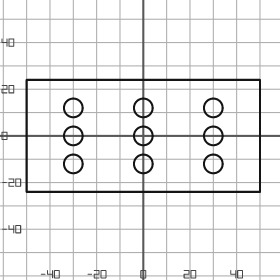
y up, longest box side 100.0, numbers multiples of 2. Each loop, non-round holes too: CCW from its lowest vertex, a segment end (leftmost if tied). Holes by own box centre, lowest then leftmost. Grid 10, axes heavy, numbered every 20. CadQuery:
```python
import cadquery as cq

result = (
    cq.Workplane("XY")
    .moveTo(-50.0, -24.0)
    .lineTo(50.0, -24.0)
    .lineTo(50.0, 24.0)
    .lineTo(-50.0, 24.0)
    .close()
    .moveTo(-30.0, -12.0)
    .circle(4.0)
    .moveTo(0.0, -12.0)
    .circle(4.0)
    .moveTo(30.0, -12.0)
    .circle(4.0)
    .moveTo(-30.0, 0.0)
    .circle(4.0)
    .moveTo(0.0, 0.0)
    .circle(4.0)
    .moveTo(30.0, 0.0)
    .circle(4.0)
    .moveTo(-30.0, 12.0)
    .circle(4.0)
    .moveTo(0.0, 12.0)
    .circle(4.0)
    .moveTo(30.0, 12.0)
    .circle(4.0)
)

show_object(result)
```